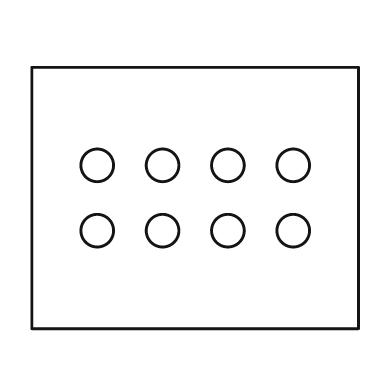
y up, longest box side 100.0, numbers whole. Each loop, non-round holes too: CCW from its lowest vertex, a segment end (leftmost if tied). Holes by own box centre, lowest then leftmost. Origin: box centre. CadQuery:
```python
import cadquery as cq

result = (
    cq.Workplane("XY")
    .moveTo(-50.0, -40.0)
    .lineTo(50.0, -40.0)
    .lineTo(50.0, 40.0)
    .lineTo(-50.0, 40.0)
    .close()
    .moveTo(-30.0, -10.0)
    .circle(5.0)
    .moveTo(-10.0, -10.0)
    .circle(5.0)
    .moveTo(10.0, -10.0)
    .circle(5.0)
    .moveTo(30.0, -10.0)
    .circle(5.0)
    .moveTo(-30.0, 10.0)
    .circle(5.0)
    .moveTo(-10.0, 10.0)
    .circle(5.0)
    .moveTo(10.0, 10.0)
    .circle(5.0)
    .moveTo(30.0, 10.0)
    .circle(5.0)
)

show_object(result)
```